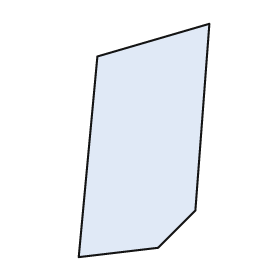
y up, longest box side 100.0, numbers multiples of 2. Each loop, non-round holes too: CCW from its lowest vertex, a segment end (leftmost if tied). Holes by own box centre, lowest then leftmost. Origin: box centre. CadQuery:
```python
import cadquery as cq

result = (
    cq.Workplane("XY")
    .moveTo(-28.0, -50.0)
    .lineTo(6.0, -46.0)
    .lineTo(22.0, -30.0)
    .lineTo(28.0, 50.0)
    .lineTo(-20.0, 36.0)
    .close()
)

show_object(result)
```